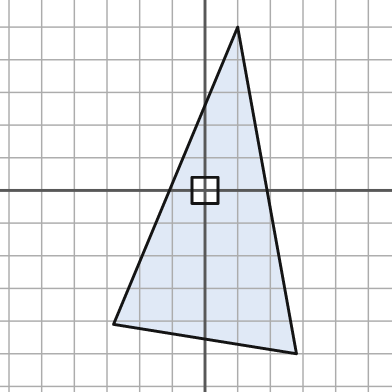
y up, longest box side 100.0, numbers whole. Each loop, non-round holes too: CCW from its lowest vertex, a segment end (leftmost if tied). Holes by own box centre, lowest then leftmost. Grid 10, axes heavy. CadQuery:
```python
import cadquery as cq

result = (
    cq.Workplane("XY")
    .moveTo(28.0, -50.0)
    .lineTo(10.0, 50.0)
    .lineTo(-28.0, -41.0)
    .close()
    .moveTo(-4.0, -4.0)
    .lineTo(4.0, -4.0)
    .lineTo(4.0, 4.0)
    .lineTo(-4.0, 4.0)
    .close()
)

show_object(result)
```